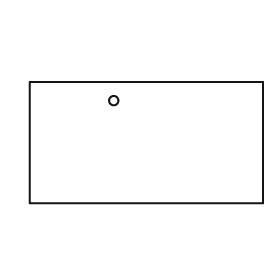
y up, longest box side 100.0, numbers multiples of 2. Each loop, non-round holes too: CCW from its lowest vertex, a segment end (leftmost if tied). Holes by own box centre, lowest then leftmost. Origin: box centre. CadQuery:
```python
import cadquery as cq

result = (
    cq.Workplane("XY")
    .moveTo(-50.0, -26.0)
    .lineTo(50.0, -26.0)
    .lineTo(50.0, 26.0)
    .lineTo(-50.0, 26.0)
    .close()
    .moveTo(-14.0, 18.0)
    .circle(2.0)
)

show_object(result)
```